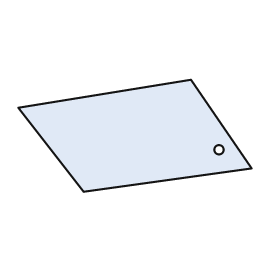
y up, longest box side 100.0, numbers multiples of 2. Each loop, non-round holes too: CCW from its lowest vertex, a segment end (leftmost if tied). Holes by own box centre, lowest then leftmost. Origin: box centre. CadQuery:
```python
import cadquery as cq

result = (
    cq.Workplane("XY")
    .moveTo(-22.0, -24.0)
    .lineTo(50.0, -14.0)
    .lineTo(24.0, 24.0)
    .lineTo(-50.0, 12.0)
    .close()
    .moveTo(36.0, -6.0)
    .circle(2.0)
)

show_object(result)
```